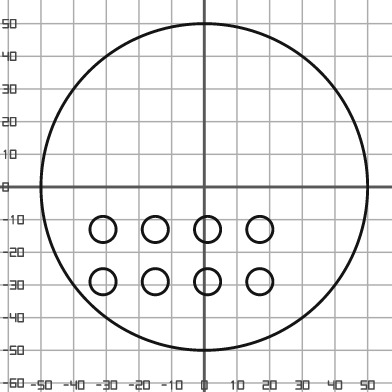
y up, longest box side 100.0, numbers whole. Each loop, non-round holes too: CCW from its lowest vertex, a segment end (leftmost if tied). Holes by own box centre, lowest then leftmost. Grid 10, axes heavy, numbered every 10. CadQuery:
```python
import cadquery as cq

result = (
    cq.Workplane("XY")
    .moveTo(0.0, 0.0)
    .circle(50.0)
    .moveTo(-31.0, -29.0)
    .circle(4.0)
    .moveTo(-15.0, -29.0)
    .circle(4.0)
    .moveTo(1.0, -29.0)
    .circle(4.0)
    .moveTo(17.0, -29.0)
    .circle(4.0)
    .moveTo(-31.0, -13.0)
    .circle(4.0)
    .moveTo(-15.0, -13.0)
    .circle(4.0)
    .moveTo(1.0, -13.0)
    .circle(4.0)
    .moveTo(17.0, -13.0)
    .circle(4.0)
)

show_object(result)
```